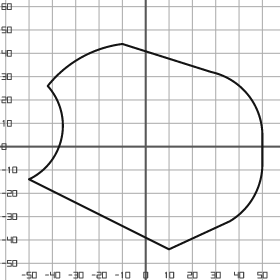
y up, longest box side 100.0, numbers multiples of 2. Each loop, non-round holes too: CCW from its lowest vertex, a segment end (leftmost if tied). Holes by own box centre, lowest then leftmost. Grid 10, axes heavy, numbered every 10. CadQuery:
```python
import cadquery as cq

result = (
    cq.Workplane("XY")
    .moveTo(10.0, -44.0)
    .lineTo(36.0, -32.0)
    .threePointArc((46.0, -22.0), (50.0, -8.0))
    .lineTo(50.0, 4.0)
    .threePointArc((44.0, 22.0), (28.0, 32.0))
    .lineTo(-10.0, 44.0)
    .threePointArc((-28.0, 38.0), (-42.0, 26.0))
    .threePointArc((-36.0, 4.0), (-50.0, -14.0))
    .close()
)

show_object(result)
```